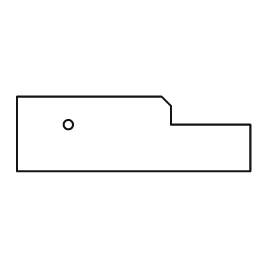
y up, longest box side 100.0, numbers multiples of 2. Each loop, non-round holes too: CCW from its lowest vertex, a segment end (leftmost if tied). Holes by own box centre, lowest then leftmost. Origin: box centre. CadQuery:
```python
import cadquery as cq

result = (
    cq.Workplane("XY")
    .moveTo(-50.0, -16.0)
    .lineTo(50.0, -16.0)
    .lineTo(50.0, 4.0)
    .lineTo(16.0, 4.0)
    .lineTo(16.0, 12.0)
    .lineTo(12.0, 16.0)
    .lineTo(-50.0, 16.0)
    .close()
    .moveTo(-28.0, 4.0)
    .circle(2.0)
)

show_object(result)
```